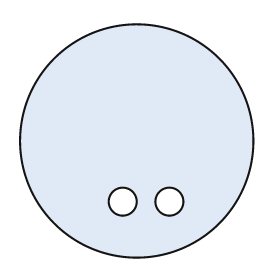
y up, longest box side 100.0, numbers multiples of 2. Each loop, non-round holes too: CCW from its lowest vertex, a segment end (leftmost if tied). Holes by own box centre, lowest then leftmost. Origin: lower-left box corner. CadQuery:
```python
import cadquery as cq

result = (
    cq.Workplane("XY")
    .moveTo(50.0, 50.0)
    .circle(50.0)
    .moveTo(44.0, 24.0)
    .circle(6.0)
    .moveTo(64.0, 24.0)
    .circle(6.0)
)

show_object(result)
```